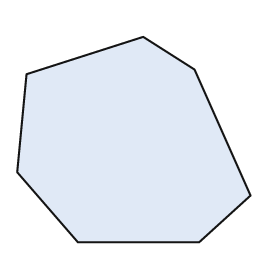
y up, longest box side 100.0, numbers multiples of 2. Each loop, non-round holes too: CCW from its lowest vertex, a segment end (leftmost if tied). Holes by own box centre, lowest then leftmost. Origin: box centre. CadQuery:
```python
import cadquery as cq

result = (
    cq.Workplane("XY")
    .moveTo(-24.0, -44.0)
    .lineTo(28.0, -44.0)
    .lineTo(50.0, -24.0)
    .lineTo(26.0, 30.0)
    .lineTo(4.0, 44.0)
    .lineTo(-46.0, 28.0)
    .lineTo(-50.0, -14.0)
    .close()
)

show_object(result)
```